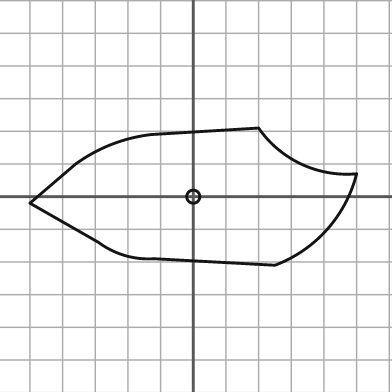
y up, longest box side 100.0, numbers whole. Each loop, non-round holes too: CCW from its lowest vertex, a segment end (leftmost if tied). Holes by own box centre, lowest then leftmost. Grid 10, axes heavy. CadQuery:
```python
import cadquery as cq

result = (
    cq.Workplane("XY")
    .moveTo(25.0, -21.0)
    .threePointArc((41.0, -10.0), (50.0, 7.0))
    .threePointArc((33.0, 10.0), (20.0, 21.0))
    .lineTo(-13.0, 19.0)
    .threePointArc((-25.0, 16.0), (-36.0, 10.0))
    .lineTo(-50.0, -2.0)
    .lineTo(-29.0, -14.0)
    .threePointArc((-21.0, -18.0), (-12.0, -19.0))
    .close()
    .moveTo(0.0, 0.0)
    .circle(2.0)
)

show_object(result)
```